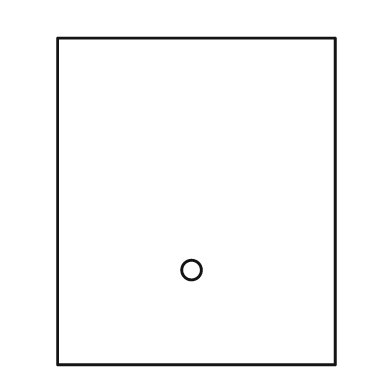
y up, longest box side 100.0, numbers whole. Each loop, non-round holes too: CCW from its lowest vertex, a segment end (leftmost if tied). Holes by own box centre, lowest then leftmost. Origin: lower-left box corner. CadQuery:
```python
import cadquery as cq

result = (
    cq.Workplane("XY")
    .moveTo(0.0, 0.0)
    .lineTo(85.0, 0.0)
    .lineTo(85.0, 100.0)
    .lineTo(0.0, 100.0)
    .close()
    .moveTo(41.0, 29.0)
    .circle(3.0)
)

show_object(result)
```